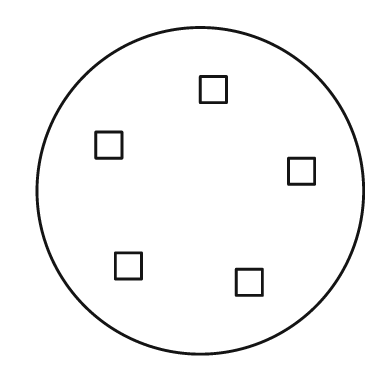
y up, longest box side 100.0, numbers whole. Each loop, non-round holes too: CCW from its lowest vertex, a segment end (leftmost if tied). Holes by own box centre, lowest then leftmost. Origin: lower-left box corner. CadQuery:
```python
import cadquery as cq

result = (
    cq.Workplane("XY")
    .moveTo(50.0, 50.0)
    .circle(50.0)
    .moveTo(61.0, 18.0)
    .lineTo(69.0, 18.0)
    .lineTo(69.0, 26.0)
    .lineTo(61.0, 26.0)
    .close()
    .moveTo(24.0, 23.0)
    .lineTo(32.0, 23.0)
    .lineTo(32.0, 31.0)
    .lineTo(24.0, 31.0)
    .close()
    .moveTo(77.0, 52.0)
    .lineTo(85.0, 52.0)
    .lineTo(85.0, 60.0)
    .lineTo(77.0, 60.0)
    .close()
    .moveTo(18.0, 60.0)
    .lineTo(26.0, 60.0)
    .lineTo(26.0, 68.0)
    .lineTo(18.0, 68.0)
    .close()
    .moveTo(50.0, 77.0)
    .lineTo(58.0, 77.0)
    .lineTo(58.0, 85.0)
    .lineTo(50.0, 85.0)
    .close()
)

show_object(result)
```